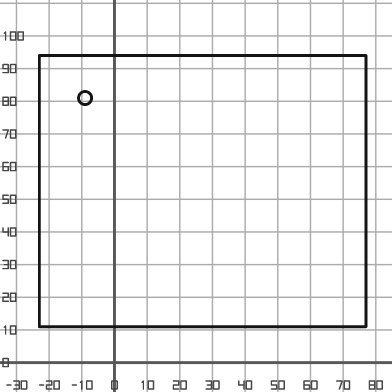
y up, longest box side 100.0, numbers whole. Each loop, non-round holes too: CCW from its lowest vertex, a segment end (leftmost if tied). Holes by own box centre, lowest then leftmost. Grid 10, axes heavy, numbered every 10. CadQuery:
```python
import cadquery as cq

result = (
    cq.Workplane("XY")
    .moveTo(-23.0, 11.0)
    .lineTo(77.0, 11.0)
    .lineTo(77.0, 94.0)
    .lineTo(-23.0, 94.0)
    .close()
    .moveTo(-9.0, 81.0)
    .circle(2.0)
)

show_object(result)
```